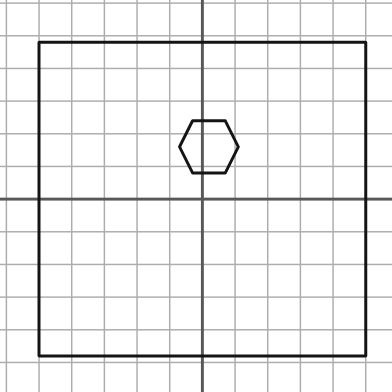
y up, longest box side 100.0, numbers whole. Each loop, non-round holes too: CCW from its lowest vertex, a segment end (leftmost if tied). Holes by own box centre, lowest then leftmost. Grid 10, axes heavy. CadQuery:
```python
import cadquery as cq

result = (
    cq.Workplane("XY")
    .moveTo(-50.0, -48.0)
    .lineTo(50.0, -48.0)
    .lineTo(50.0, 48.0)
    .lineTo(-50.0, 48.0)
    .close()
    .moveTo(-3.0, 8.0)
    .lineTo(7.0, 8.0)
    .lineTo(11.0, 16.0)
    .lineTo(7.0, 24.0)
    .lineTo(-3.0, 24.0)
    .lineTo(-7.0, 16.0)
    .close()
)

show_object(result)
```